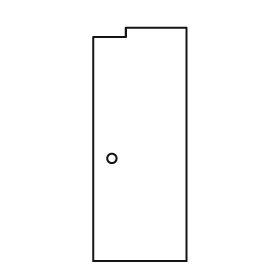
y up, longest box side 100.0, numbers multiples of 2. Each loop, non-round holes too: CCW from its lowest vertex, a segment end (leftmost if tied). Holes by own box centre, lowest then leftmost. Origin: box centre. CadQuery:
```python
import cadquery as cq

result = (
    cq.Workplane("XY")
    .moveTo(-20.0, -50.0)
    .lineTo(20.0, -50.0)
    .lineTo(20.0, 50.0)
    .lineTo(-6.0, 50.0)
    .lineTo(-6.0, 46.0)
    .lineTo(-20.0, 46.0)
    .close()
    .moveTo(-12.0, -6.0)
    .circle(2.0)
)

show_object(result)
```